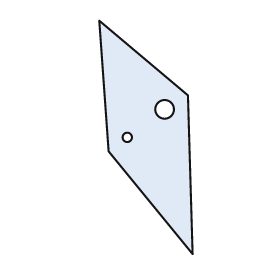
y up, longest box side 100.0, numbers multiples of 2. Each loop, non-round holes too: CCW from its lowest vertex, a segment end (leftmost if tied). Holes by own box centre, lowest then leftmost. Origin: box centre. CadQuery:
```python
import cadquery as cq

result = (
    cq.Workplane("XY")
    .moveTo(20.0, -50.0)
    .lineTo(18.0, 18.0)
    .lineTo(-20.0, 50.0)
    .lineTo(-16.0, -6.0)
    .close()
    .moveTo(-8.0, 0.0)
    .circle(2.0)
    .moveTo(8.0, 12.0)
    .circle(4.0)
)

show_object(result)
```